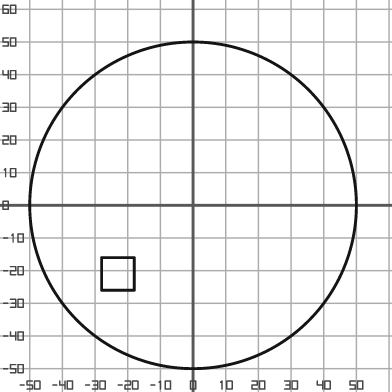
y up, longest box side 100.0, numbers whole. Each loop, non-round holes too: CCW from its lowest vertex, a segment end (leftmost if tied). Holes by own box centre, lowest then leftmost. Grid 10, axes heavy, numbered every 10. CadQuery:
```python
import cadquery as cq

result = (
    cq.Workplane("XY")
    .moveTo(0.0, 0.0)
    .circle(50.0)
    .moveTo(-28.0, -26.0)
    .lineTo(-18.0, -26.0)
    .lineTo(-18.0, -16.0)
    .lineTo(-28.0, -16.0)
    .close()
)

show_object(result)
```